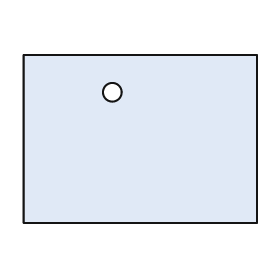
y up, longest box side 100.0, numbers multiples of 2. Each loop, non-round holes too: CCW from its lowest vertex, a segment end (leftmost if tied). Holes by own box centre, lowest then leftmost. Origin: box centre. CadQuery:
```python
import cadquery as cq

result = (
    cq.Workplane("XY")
    .moveTo(-50.0, -36.0)
    .lineTo(50.0, -36.0)
    .lineTo(50.0, 36.0)
    .lineTo(-50.0, 36.0)
    .close()
    .moveTo(-12.0, 20.0)
    .circle(4.0)
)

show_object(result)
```